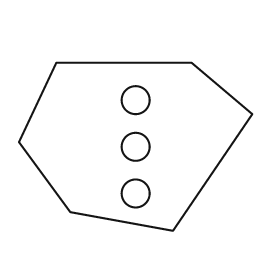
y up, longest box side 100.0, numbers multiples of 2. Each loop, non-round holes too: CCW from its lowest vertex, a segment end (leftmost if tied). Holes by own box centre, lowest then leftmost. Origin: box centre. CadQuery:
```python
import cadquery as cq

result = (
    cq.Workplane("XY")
    .moveTo(16.0, -36.0)
    .lineTo(50.0, 14.0)
    .lineTo(24.0, 36.0)
    .lineTo(-34.0, 36.0)
    .lineTo(-50.0, 2.0)
    .lineTo(-28.0, -28.0)
    .close()
    .moveTo(0.0, -20.0)
    .circle(6.0)
    .moveTo(0.0, 0.0)
    .circle(6.0)
    .moveTo(0.0, 20.0)
    .circle(6.0)
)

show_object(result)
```